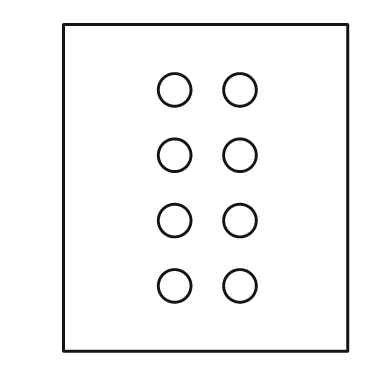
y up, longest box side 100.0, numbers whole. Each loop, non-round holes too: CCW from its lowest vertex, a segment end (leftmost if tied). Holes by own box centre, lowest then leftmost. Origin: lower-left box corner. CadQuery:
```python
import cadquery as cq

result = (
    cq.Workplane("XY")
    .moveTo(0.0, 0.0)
    .lineTo(87.0, 0.0)
    .lineTo(87.0, 100.0)
    .lineTo(0.0, 100.0)
    .close()
    .moveTo(34.0, 20.0)
    .circle(5.0)
    .moveTo(54.0, 20.0)
    .circle(5.0)
    .moveTo(34.0, 40.0)
    .circle(5.0)
    .moveTo(54.0, 40.0)
    .circle(5.0)
    .moveTo(34.0, 60.0)
    .circle(5.0)
    .moveTo(54.0, 60.0)
    .circle(5.0)
    .moveTo(34.0, 80.0)
    .circle(5.0)
    .moveTo(54.0, 80.0)
    .circle(5.0)
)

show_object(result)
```